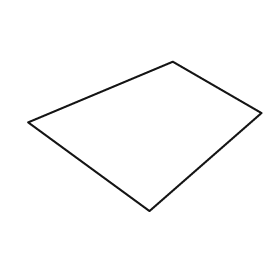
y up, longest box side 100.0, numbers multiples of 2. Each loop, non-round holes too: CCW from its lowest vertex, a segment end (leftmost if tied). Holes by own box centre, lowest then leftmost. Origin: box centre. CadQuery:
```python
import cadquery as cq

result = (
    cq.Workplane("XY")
    .moveTo(2.0, -32.0)
    .lineTo(50.0, 10.0)
    .lineTo(12.0, 32.0)
    .lineTo(-50.0, 6.0)
    .close()
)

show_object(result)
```